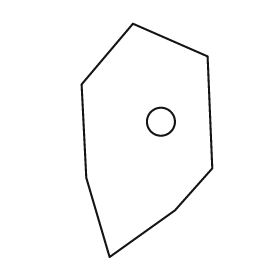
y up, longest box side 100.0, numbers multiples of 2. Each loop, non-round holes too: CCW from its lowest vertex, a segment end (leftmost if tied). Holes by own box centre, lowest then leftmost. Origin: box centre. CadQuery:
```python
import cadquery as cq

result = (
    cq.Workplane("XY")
    .moveTo(-16.0, -50.0)
    .lineTo(12.0, -30.0)
    .lineTo(28.0, -12.0)
    .lineTo(26.0, 36.0)
    .lineTo(-6.0, 50.0)
    .lineTo(-28.0, 24.0)
    .lineTo(-26.0, -16.0)
    .close()
    .moveTo(6.0, 8.0)
    .circle(6.0)
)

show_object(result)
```